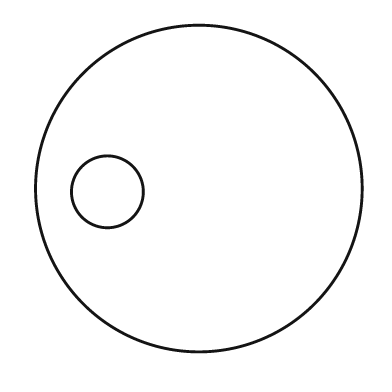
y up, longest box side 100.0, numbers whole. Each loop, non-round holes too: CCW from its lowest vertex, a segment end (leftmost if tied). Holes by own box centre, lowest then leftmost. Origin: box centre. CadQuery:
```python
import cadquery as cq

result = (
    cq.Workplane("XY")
    .moveTo(0.0, 0.0)
    .circle(50.0)
    .moveTo(-28.0, -1.0)
    .circle(11.0)
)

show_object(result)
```